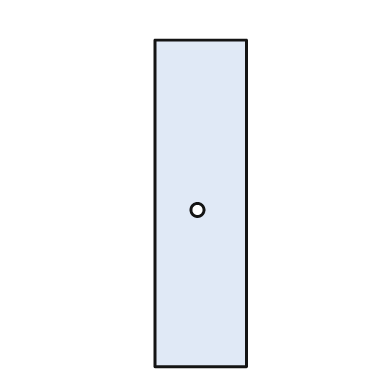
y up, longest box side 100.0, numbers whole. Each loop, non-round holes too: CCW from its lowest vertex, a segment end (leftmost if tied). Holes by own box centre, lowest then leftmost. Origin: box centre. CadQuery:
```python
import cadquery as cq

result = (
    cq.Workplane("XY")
    .moveTo(-14.0, -50.0)
    .lineTo(14.0, -50.0)
    .lineTo(14.0, 50.0)
    .lineTo(-14.0, 50.0)
    .close()
    .moveTo(-1.0, -2.0)
    .circle(2.0)
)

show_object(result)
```